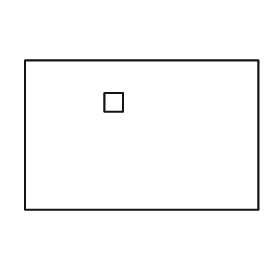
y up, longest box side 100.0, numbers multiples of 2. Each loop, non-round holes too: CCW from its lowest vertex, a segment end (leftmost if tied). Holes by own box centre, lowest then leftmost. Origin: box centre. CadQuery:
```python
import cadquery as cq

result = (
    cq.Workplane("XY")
    .moveTo(-50.0, -32.0)
    .lineTo(50.0, -32.0)
    .lineTo(50.0, 32.0)
    .lineTo(-50.0, 32.0)
    .close()
    .moveTo(-16.0, 10.0)
    .lineTo(-8.0, 10.0)
    .lineTo(-8.0, 18.0)
    .lineTo(-16.0, 18.0)
    .close()
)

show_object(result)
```